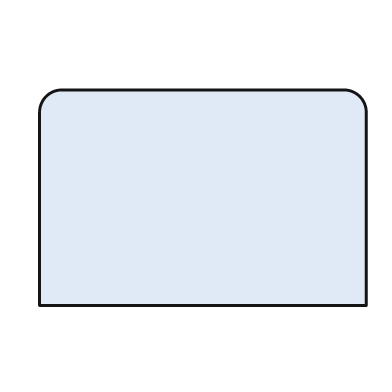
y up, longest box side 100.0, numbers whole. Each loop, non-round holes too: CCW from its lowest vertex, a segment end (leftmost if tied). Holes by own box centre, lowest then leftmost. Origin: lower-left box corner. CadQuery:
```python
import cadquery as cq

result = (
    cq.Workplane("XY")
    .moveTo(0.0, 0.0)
    .lineTo(100.0, 0.0)
    .lineTo(100.0, 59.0)
    .threePointArc((98.0, 64.0), (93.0, 66.0))
    .lineTo(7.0, 66.0)
    .threePointArc((2.0, 64.0), (0.0, 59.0))
    .close()
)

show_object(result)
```